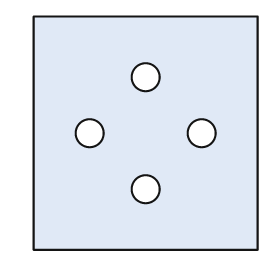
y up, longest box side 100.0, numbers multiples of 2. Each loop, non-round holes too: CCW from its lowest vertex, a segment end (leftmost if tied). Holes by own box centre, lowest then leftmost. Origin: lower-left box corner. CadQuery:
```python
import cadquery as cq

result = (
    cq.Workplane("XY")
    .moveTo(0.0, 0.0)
    .lineTo(96.0, 0.0)
    .lineTo(96.0, 100.0)
    .lineTo(0.0, 100.0)
    .close()
    .moveTo(48.0, 26.0)
    .circle(6.0)
    .moveTo(24.0, 50.0)
    .circle(6.0)
    .moveTo(72.0, 50.0)
    .circle(6.0)
    .moveTo(48.0, 74.0)
    .circle(6.0)
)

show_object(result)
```